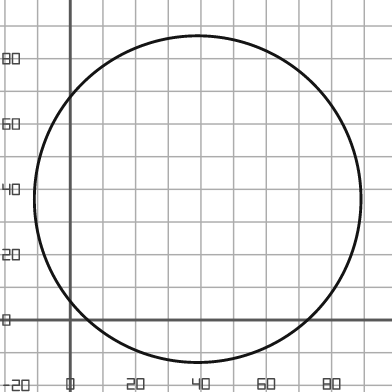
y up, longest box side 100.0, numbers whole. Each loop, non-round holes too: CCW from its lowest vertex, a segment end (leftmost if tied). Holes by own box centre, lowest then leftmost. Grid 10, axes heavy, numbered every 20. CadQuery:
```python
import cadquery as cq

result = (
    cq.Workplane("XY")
    .moveTo(39.0, 37.0)
    .circle(50.0)
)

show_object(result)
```